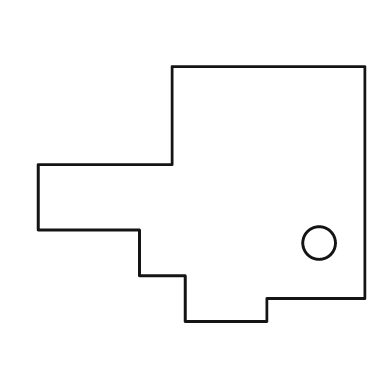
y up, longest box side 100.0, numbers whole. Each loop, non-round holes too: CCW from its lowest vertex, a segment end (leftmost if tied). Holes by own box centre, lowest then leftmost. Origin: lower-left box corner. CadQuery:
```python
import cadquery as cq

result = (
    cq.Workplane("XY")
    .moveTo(45.0, 0.0)
    .lineTo(70.0, 0.0)
    .lineTo(70.0, 7.0)
    .lineTo(100.0, 7.0)
    .lineTo(100.0, 78.0)
    .lineTo(41.0, 78.0)
    .lineTo(41.0, 48.0)
    .lineTo(0.0, 48.0)
    .lineTo(0.0, 28.0)
    .lineTo(31.0, 28.0)
    .lineTo(31.0, 14.0)
    .lineTo(45.0, 14.0)
    .close()
    .moveTo(86.0, 24.0)
    .circle(5.0)
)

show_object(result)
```